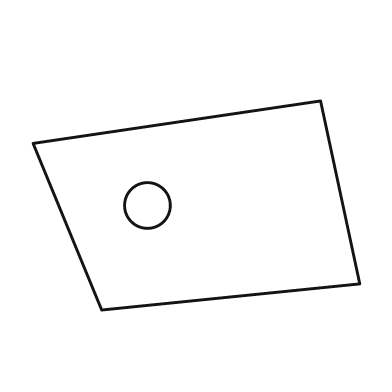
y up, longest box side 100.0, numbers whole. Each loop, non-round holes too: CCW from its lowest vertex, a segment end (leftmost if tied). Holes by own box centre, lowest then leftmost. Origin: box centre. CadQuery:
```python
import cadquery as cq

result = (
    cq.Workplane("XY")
    .moveTo(-29.0, -32.0)
    .lineTo(50.0, -24.0)
    .lineTo(38.0, 32.0)
    .lineTo(-50.0, 19.0)
    .close()
    .moveTo(-15.0, 0.0)
    .circle(7.0)
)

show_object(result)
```